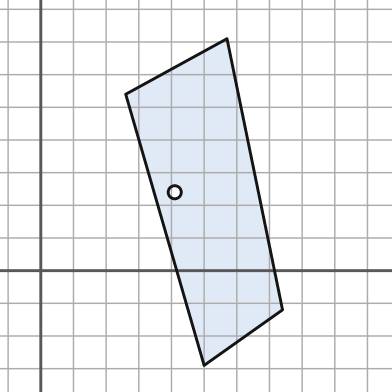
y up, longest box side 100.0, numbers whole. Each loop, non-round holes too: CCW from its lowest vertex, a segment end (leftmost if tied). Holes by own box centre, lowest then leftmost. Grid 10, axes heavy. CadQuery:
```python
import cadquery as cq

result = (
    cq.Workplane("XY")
    .moveTo(50.0, -29.0)
    .lineTo(74.0, -12.0)
    .lineTo(57.0, 71.0)
    .lineTo(26.0, 54.0)
    .close()
    .moveTo(41.0, 24.0)
    .circle(2.0)
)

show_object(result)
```